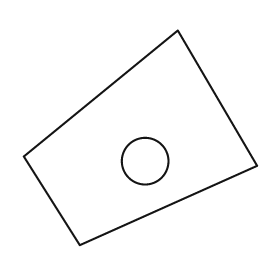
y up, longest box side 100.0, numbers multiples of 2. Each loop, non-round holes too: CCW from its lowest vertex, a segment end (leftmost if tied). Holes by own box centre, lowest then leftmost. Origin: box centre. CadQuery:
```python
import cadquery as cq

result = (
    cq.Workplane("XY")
    .moveTo(-26.0, -46.0)
    .lineTo(50.0, -12.0)
    .lineTo(16.0, 46.0)
    .lineTo(-50.0, -8.0)
    .close()
    .moveTo(2.0, -10.0)
    .circle(10.0)
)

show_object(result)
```